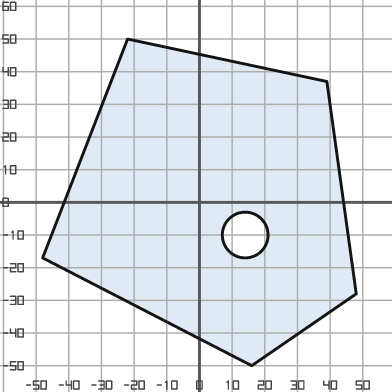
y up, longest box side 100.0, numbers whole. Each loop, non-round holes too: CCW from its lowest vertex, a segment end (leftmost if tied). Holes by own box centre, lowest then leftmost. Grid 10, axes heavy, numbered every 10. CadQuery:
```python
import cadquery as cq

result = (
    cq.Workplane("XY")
    .moveTo(16.0, -50.0)
    .lineTo(48.0, -28.0)
    .lineTo(39.0, 37.0)
    .lineTo(-22.0, 50.0)
    .lineTo(-48.0, -17.0)
    .close()
    .moveTo(14.0, -10.0)
    .circle(7.0)
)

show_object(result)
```